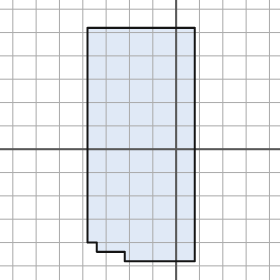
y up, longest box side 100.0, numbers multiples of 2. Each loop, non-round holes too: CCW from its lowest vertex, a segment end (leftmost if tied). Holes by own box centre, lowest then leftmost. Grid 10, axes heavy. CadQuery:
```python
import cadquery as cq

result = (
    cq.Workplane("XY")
    .moveTo(-22.0, -48.0)
    .lineTo(8.0, -48.0)
    .lineTo(8.0, 52.0)
    .lineTo(-38.0, 52.0)
    .lineTo(-38.0, -40.0)
    .lineTo(-34.0, -40.0)
    .lineTo(-34.0, -44.0)
    .lineTo(-22.0, -44.0)
    .close()
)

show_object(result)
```